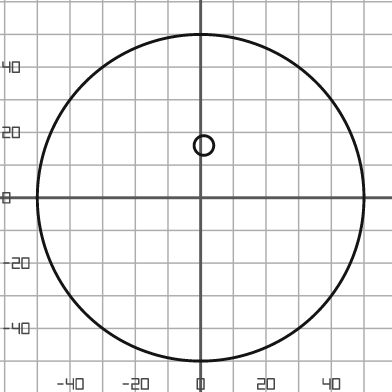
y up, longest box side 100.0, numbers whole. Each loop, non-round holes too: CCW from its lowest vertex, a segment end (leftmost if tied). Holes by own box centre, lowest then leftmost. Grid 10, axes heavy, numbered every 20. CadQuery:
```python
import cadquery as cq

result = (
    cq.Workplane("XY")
    .moveTo(0.0, 0.0)
    .circle(50.0)
    .moveTo(1.0, 16.0)
    .circle(3.0)
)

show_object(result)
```